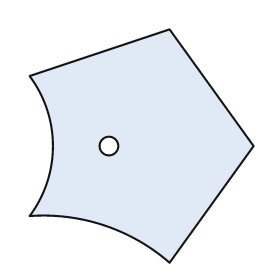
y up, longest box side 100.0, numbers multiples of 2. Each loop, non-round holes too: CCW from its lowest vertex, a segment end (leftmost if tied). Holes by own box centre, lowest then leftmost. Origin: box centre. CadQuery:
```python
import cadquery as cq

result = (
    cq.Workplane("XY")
    .moveTo(12.0, -50.0)
    .lineTo(48.0, 0.0)
    .lineTo(12.0, 50.0)
    .lineTo(-48.0, 30.0)
    .threePointArc((-38.0, 0.0), (-48.0, -30.0))
    .threePointArc((-16.0, -34.0), (12.0, -50.0))
    .close()
    .moveTo(-14.0, 0.0)
    .circle(4.0)
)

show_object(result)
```